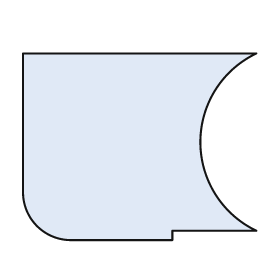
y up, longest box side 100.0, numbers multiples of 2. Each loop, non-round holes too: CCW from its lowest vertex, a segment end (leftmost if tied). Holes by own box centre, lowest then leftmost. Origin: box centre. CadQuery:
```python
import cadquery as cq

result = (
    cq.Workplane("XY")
    .moveTo(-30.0, -40.0)
    .lineTo(14.0, -40.0)
    .lineTo(14.0, -36.0)
    .lineTo(50.0, -36.0)
    .threePointArc((26.0, 2.0), (50.0, 40.0))
    .lineTo(-50.0, 40.0)
    .lineTo(-50.0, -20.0)
    .threePointArc((-44.0, -34.0), (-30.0, -40.0))
    .close()
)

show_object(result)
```